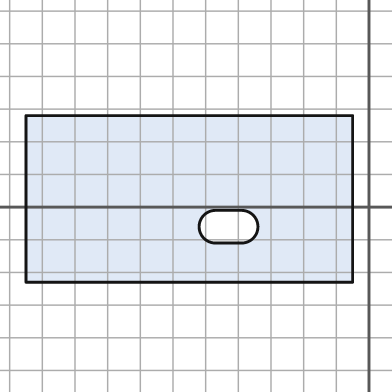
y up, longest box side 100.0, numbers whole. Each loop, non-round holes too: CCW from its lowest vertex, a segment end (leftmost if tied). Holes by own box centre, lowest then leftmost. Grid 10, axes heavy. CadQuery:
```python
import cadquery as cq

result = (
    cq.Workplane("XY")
    .moveTo(-105.0, -23.0)
    .lineTo(-5.0, -23.0)
    .lineTo(-5.0, 28.0)
    .lineTo(-105.0, 28.0)
    .close()
    .moveTo(-47.0, -11.0)
    .lineTo(-39.0, -11.0)
    .threePointArc((-34.0, -6.0), (-39.0, -1.0))
    .lineTo(-47.0, -1.0)
    .threePointArc((-52.0, -6.0), (-47.0, -11.0))
    .close()
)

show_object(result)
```